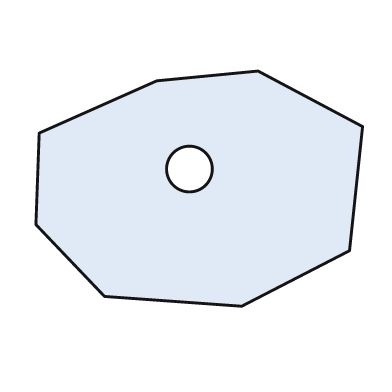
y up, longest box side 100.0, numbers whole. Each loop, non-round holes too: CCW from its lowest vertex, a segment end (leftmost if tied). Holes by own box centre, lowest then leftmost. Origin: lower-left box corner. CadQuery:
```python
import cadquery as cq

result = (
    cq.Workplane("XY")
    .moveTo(63.0, 0.0)
    .lineTo(96.0, 17.0)
    .lineTo(100.0, 55.0)
    .lineTo(68.0, 72.0)
    .lineTo(37.0, 69.0)
    .lineTo(1.0, 53.0)
    .lineTo(0.0, 25.0)
    .lineTo(21.0, 3.0)
    .close()
    .moveTo(47.0, 42.0)
    .circle(7.0)
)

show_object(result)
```